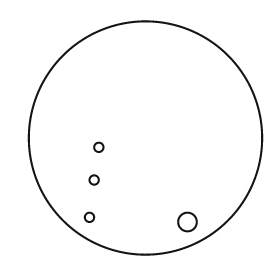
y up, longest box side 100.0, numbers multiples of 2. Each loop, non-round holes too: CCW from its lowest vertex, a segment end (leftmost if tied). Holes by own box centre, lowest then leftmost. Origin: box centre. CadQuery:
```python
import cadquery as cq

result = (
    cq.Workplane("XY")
    .moveTo(0.0, 0.0)
    .circle(50.0)
    .moveTo(18.0, -36.0)
    .circle(4.0)
    .moveTo(-24.0, -34.0)
    .circle(2.0)
    .moveTo(-22.0, -18.0)
    .circle(2.0)
    .moveTo(-20.0, -4.0)
    .circle(2.0)
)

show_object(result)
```